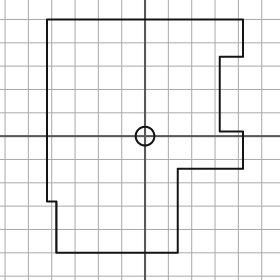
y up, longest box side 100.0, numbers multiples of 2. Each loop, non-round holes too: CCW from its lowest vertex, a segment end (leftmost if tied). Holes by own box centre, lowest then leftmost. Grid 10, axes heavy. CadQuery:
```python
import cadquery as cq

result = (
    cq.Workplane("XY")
    .moveTo(-38.0, -50.0)
    .lineTo(14.0, -50.0)
    .lineTo(14.0, -14.0)
    .lineTo(42.0, -14.0)
    .lineTo(42.0, 2.0)
    .lineTo(32.0, 2.0)
    .lineTo(32.0, 34.0)
    .lineTo(42.0, 34.0)
    .lineTo(42.0, 50.0)
    .lineTo(-42.0, 50.0)
    .lineTo(-42.0, -28.0)
    .lineTo(-38.0, -28.0)
    .close()
    .moveTo(0.0, 0.0)
    .circle(4.0)
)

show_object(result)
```